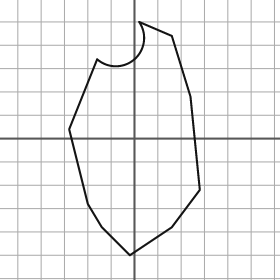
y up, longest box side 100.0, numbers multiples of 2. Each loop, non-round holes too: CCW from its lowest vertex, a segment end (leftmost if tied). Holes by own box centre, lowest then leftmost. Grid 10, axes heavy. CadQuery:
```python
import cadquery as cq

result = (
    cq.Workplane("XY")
    .moveTo(-2.0, -50.0)
    .lineTo(16.0, -38.0)
    .lineTo(28.0, -22.0)
    .lineTo(24.0, 18.0)
    .lineTo(16.0, 44.0)
    .lineTo(2.0, 50.0)
    .threePointArc((0.0, 34.0), (-16.0, 34.0))
    .lineTo(-28.0, 4.0)
    .lineTo(-20.0, -28.0)
    .lineTo(-14.0, -38.0)
    .close()
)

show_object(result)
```